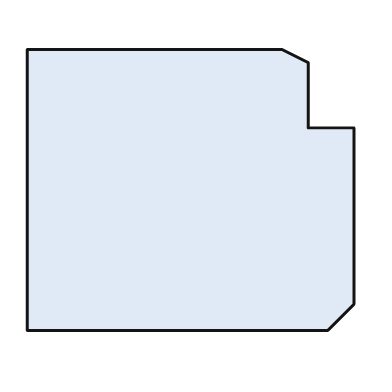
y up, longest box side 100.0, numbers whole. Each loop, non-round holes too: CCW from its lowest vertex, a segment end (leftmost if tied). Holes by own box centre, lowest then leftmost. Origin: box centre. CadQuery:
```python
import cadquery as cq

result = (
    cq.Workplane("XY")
    .moveTo(-50.0, -43.0)
    .lineTo(42.0, -43.0)
    .lineTo(50.0, -35.0)
    .lineTo(50.0, 19.0)
    .lineTo(36.0, 19.0)
    .lineTo(36.0, 39.0)
    .lineTo(28.0, 43.0)
    .lineTo(-50.0, 43.0)
    .close()
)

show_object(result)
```